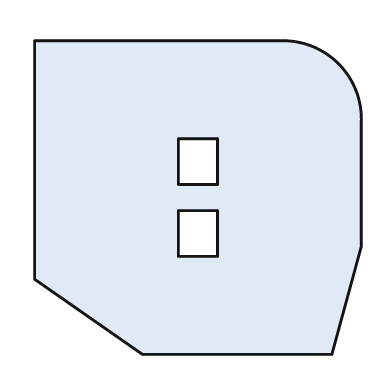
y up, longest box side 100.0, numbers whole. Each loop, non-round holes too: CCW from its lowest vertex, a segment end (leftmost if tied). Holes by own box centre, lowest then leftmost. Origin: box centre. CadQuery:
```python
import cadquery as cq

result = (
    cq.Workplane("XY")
    .moveTo(-17.0, -48.0)
    .lineTo(41.0, -48.0)
    .lineTo(50.0, -15.0)
    .lineTo(50.0, 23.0)
    .threePointArc((43.0, 41.0), (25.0, 48.0))
    .lineTo(-50.0, 48.0)
    .lineTo(-50.0, -25.0)
    .close()
    .moveTo(-6.0, -18.0)
    .lineTo(6.0, -18.0)
    .lineTo(6.0, -4.0)
    .lineTo(-6.0, -4.0)
    .close()
    .moveTo(-6.0, 4.0)
    .lineTo(6.0, 4.0)
    .lineTo(6.0, 18.0)
    .lineTo(-6.0, 18.0)
    .close()
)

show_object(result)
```